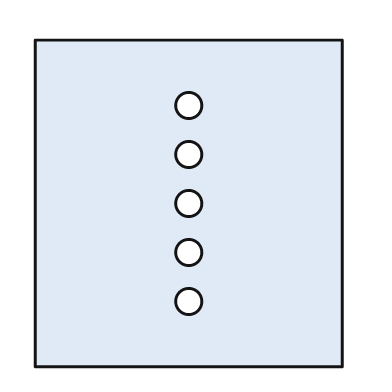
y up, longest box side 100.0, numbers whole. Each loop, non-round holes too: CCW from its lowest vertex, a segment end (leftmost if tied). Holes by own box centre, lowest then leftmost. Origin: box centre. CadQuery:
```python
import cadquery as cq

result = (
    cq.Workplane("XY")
    .moveTo(-47.0, -50.0)
    .lineTo(47.0, -50.0)
    .lineTo(47.0, 50.0)
    .lineTo(-47.0, 50.0)
    .close()
    .moveTo(0.0, -30.0)
    .circle(4.0)
    .moveTo(0.0, -15.0)
    .circle(4.0)
    .moveTo(0.0, 0.0)
    .circle(4.0)
    .moveTo(0.0, 15.0)
    .circle(4.0)
    .moveTo(0.0, 30.0)
    .circle(4.0)
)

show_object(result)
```